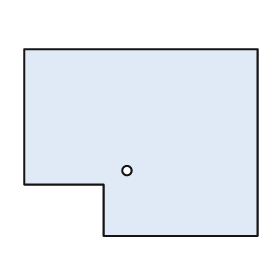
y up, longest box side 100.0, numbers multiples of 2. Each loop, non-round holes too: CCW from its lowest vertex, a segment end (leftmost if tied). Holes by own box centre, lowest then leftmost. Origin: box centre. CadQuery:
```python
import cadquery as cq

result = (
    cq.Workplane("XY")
    .moveTo(-16.0, -40.0)
    .lineTo(50.0, -40.0)
    .lineTo(50.0, 40.0)
    .lineTo(-50.0, 40.0)
    .lineTo(-50.0, -18.0)
    .lineTo(-16.0, -18.0)
    .close()
    .moveTo(-6.0, -12.0)
    .circle(2.0)
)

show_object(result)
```